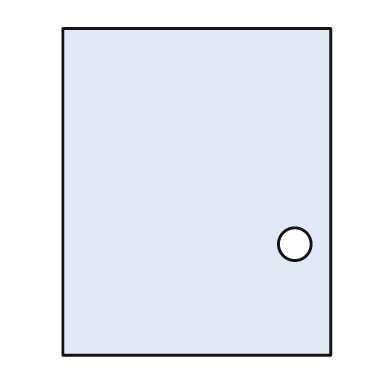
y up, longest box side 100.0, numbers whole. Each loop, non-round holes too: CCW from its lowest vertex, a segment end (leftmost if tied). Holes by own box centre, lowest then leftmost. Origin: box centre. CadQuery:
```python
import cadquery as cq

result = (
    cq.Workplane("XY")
    .moveTo(-41.0, -50.0)
    .lineTo(41.0, -50.0)
    .lineTo(41.0, 50.0)
    .lineTo(-41.0, 50.0)
    .close()
    .moveTo(30.0, -16.0)
    .circle(5.0)
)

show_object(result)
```